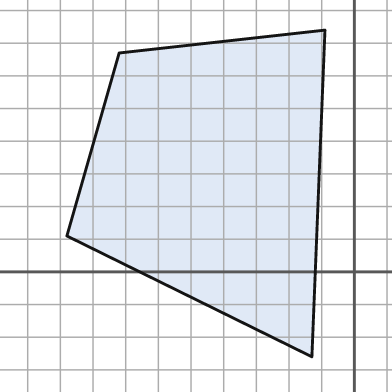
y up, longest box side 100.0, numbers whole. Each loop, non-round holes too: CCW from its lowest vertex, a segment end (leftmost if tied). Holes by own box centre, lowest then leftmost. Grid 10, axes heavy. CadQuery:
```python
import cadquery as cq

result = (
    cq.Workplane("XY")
    .moveTo(-13.0, -26.0)
    .lineTo(-9.0, 74.0)
    .lineTo(-72.0, 67.0)
    .lineTo(-88.0, 11.0)
    .close()
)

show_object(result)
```